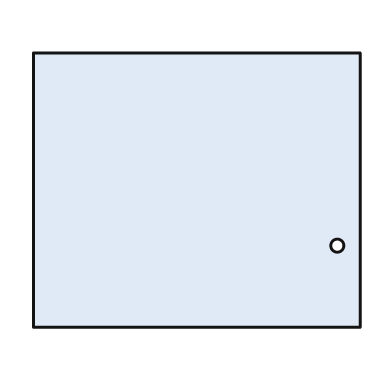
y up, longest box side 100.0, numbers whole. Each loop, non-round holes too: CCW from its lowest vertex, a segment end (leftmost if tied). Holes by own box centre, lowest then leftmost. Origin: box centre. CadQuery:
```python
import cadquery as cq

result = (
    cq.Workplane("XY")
    .moveTo(-50.0, -42.0)
    .lineTo(50.0, -42.0)
    .lineTo(50.0, 42.0)
    .lineTo(-50.0, 42.0)
    .close()
    .moveTo(43.0, -17.0)
    .circle(2.0)
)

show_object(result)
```